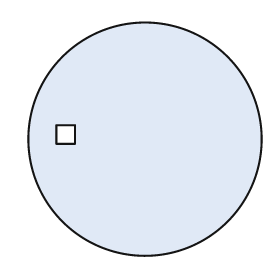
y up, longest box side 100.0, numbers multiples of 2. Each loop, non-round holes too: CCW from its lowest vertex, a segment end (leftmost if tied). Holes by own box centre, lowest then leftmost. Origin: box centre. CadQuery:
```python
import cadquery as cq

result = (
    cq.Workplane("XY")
    .moveTo(0.0, 0.0)
    .circle(50.0)
    .moveTo(-38.0, -2.0)
    .lineTo(-30.0, -2.0)
    .lineTo(-30.0, 6.0)
    .lineTo(-38.0, 6.0)
    .close()
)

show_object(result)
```